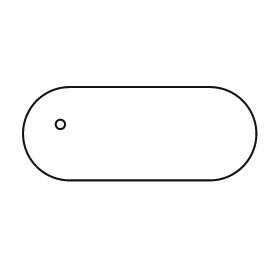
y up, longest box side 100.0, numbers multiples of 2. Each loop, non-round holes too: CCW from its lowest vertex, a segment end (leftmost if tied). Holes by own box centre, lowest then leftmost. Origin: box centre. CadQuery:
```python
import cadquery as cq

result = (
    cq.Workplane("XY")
    .moveTo(-30.0, -20.0)
    .lineTo(30.0, -20.0)
    .threePointArc((50.0, 0.0), (30.0, 20.0))
    .lineTo(-30.0, 20.0)
    .threePointArc((-50.0, 0.0), (-30.0, -20.0))
    .close()
    .moveTo(-34.0, 4.0)
    .circle(2.0)
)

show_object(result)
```